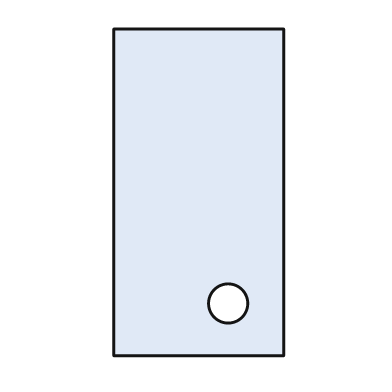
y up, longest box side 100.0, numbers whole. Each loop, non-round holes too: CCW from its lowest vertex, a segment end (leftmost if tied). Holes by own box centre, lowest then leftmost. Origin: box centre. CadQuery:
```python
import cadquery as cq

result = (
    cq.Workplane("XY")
    .moveTo(-26.0, -50.0)
    .lineTo(26.0, -50.0)
    .lineTo(26.0, 50.0)
    .lineTo(-26.0, 50.0)
    .close()
    .moveTo(9.0, -34.0)
    .circle(6.0)
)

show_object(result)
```